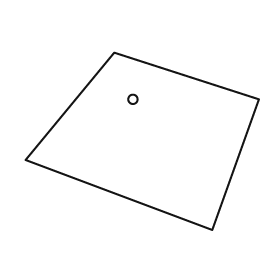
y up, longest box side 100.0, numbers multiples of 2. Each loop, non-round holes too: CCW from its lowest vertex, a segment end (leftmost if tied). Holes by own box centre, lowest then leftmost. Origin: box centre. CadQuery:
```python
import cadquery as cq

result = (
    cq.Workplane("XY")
    .moveTo(30.0, -38.0)
    .lineTo(50.0, 18.0)
    .lineTo(-12.0, 38.0)
    .lineTo(-50.0, -8.0)
    .close()
    .moveTo(-4.0, 18.0)
    .circle(2.0)
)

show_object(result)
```